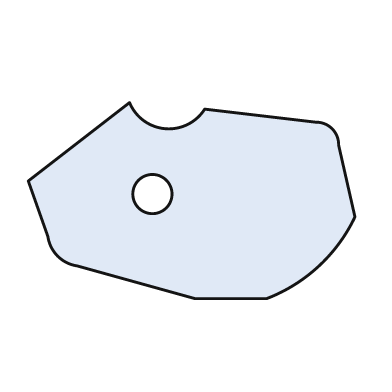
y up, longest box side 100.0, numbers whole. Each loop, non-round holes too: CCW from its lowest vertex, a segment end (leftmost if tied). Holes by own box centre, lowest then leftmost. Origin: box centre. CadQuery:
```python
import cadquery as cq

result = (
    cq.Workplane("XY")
    .moveTo(1.0, -30.0)
    .lineTo(23.0, -30.0)
    .threePointArc((39.0, -20.0), (50.0, -5.0))
    .lineTo(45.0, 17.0)
    .threePointArc((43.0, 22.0), (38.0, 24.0))
    .lineTo(4.0, 28.0)
    .threePointArc((-8.0, 22.0), (-19.0, 30.0))
    .lineTo(-50.0, 6.0)
    .lineTo(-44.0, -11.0)
    .threePointArc((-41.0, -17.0), (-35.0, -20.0))
    .close()
    .moveTo(-12.0, 2.0)
    .circle(6.0)
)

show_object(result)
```